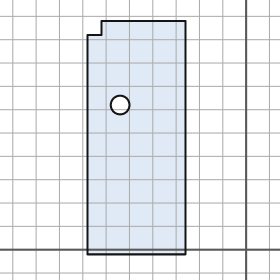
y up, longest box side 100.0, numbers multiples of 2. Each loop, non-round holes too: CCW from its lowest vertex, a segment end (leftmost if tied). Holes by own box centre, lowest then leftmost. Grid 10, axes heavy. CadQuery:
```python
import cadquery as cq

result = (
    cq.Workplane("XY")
    .moveTo(-68.0, -2.0)
    .lineTo(-26.0, -2.0)
    .lineTo(-26.0, 98.0)
    .lineTo(-62.0, 98.0)
    .lineTo(-62.0, 92.0)
    .lineTo(-68.0, 92.0)
    .close()
    .moveTo(-54.0, 62.0)
    .circle(4.0)
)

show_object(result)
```